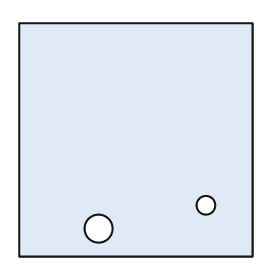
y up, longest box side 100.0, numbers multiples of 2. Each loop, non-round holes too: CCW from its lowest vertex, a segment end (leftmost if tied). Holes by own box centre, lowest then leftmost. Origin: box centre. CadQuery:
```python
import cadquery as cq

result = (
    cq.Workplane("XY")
    .moveTo(-50.0, -50.0)
    .lineTo(50.0, -50.0)
    .lineTo(50.0, 50.0)
    .lineTo(-50.0, 50.0)
    .close()
    .moveTo(-16.0, -38.0)
    .circle(6.0)
    .moveTo(30.0, -28.0)
    .circle(4.0)
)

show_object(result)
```